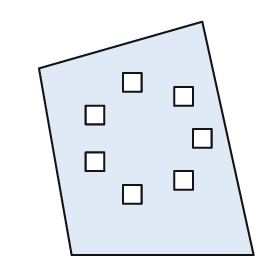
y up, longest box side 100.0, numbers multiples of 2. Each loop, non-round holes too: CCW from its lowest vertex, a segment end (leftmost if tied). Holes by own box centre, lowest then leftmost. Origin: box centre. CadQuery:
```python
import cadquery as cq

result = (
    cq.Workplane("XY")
    .moveTo(-32.0, -50.0)
    .lineTo(46.0, -50.0)
    .lineTo(24.0, 50.0)
    .lineTo(-46.0, 30.0)
    .close()
    .moveTo(-10.0, -28.0)
    .lineTo(-2.0, -28.0)
    .lineTo(-2.0, -20.0)
    .lineTo(-10.0, -20.0)
    .close()
    .moveTo(12.0, -22.0)
    .lineTo(20.0, -22.0)
    .lineTo(20.0, -14.0)
    .lineTo(12.0, -14.0)
    .close()
    .moveTo(-26.0, -14.0)
    .lineTo(-18.0, -14.0)
    .lineTo(-18.0, -6.0)
    .lineTo(-26.0, -6.0)
    .close()
    .moveTo(20.0, -4.0)
    .lineTo(28.0, -4.0)
    .lineTo(28.0, 4.0)
    .lineTo(20.0, 4.0)
    .close()
    .moveTo(-26.0, 6.0)
    .lineTo(-18.0, 6.0)
    .lineTo(-18.0, 14.0)
    .lineTo(-26.0, 14.0)
    .close()
    .moveTo(12.0, 14.0)
    .lineTo(20.0, 14.0)
    .lineTo(20.0, 22.0)
    .lineTo(12.0, 22.0)
    .close()
    .moveTo(-10.0, 20.0)
    .lineTo(-2.0, 20.0)
    .lineTo(-2.0, 28.0)
    .lineTo(-10.0, 28.0)
    .close()
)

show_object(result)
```